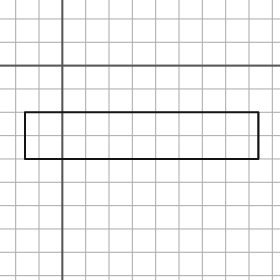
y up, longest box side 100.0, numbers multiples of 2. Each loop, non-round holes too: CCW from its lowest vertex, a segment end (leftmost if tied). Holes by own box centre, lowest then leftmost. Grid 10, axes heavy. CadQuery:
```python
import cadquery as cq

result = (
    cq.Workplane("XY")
    .moveTo(-16.0, -40.0)
    .lineTo(84.0, -40.0)
    .lineTo(84.0, -20.0)
    .lineTo(-16.0, -20.0)
    .close()
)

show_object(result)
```